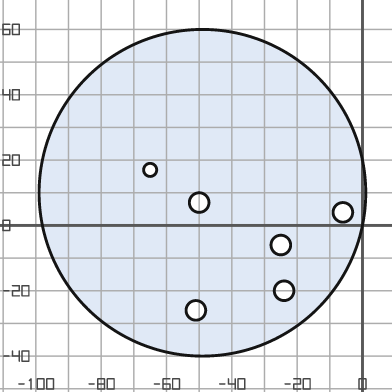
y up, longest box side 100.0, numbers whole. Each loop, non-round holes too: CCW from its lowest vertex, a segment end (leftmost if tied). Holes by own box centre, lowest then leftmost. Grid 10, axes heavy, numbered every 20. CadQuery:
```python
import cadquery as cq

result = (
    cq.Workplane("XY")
    .moveTo(-49.0, 10.0)
    .circle(50.0)
    .moveTo(-51.0, -26.0)
    .circle(3.0)
    .moveTo(-24.0, -20.0)
    .circle(3.0)
    .moveTo(-25.0, -6.0)
    .circle(3.0)
    .moveTo(-6.0, 4.0)
    .circle(3.0)
    .moveTo(-50.0, 7.0)
    .circle(3.0)
    .moveTo(-65.0, 17.0)
    .circle(2.0)
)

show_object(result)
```